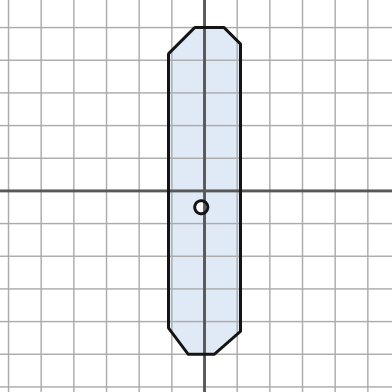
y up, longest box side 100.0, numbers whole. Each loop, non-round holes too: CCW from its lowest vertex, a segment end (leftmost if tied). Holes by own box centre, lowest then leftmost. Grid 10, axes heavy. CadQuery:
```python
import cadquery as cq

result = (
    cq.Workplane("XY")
    .moveTo(-5.0, -50.0)
    .lineTo(3.0, -50.0)
    .lineTo(11.0, -43.0)
    .lineTo(11.0, 45.0)
    .lineTo(6.0, 50.0)
    .lineTo(-3.0, 50.0)
    .lineTo(-11.0, 42.0)
    .lineTo(-11.0, -42.0)
    .close()
    .moveTo(-1.0, -5.0)
    .circle(2.0)
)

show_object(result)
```